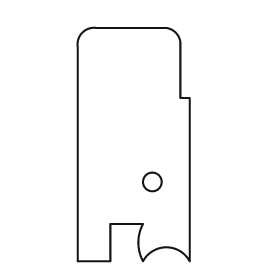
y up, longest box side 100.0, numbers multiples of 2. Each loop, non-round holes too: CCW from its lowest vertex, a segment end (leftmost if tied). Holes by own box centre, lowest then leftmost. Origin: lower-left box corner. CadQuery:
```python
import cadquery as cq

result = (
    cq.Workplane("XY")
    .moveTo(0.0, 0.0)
    .lineTo(14.0, 0.0)
    .lineTo(14.0, 16.0)
    .lineTo(28.0, 16.0)
    .threePointArc((26.0, 8.0), (28.0, 0.0))
    .threePointArc((38.0, 6.0), (48.0, 0.0))
    .lineTo(48.0, 70.0)
    .lineTo(44.0, 70.0)
    .lineTo(44.0, 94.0)
    .threePointArc((42.0, 98.0), (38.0, 100.0))
    .lineTo(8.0, 100.0)
    .threePointArc((2.0, 98.0), (0.0, 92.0))
    .close()
    .moveTo(32.0, 34.0)
    .circle(4.0)
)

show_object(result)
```